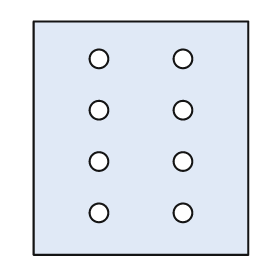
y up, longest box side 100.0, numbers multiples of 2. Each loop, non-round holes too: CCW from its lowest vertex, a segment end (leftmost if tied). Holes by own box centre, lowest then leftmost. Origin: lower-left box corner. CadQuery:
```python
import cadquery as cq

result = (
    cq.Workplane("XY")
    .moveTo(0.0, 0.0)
    .lineTo(92.0, 0.0)
    .lineTo(92.0, 100.0)
    .lineTo(0.0, 100.0)
    .close()
    .moveTo(28.0, 18.0)
    .circle(4.0)
    .moveTo(64.0, 18.0)
    .circle(4.0)
    .moveTo(28.0, 40.0)
    .circle(4.0)
    .moveTo(64.0, 40.0)
    .circle(4.0)
    .moveTo(28.0, 62.0)
    .circle(4.0)
    .moveTo(64.0, 62.0)
    .circle(4.0)
    .moveTo(28.0, 84.0)
    .circle(4.0)
    .moveTo(64.0, 84.0)
    .circle(4.0)
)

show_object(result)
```